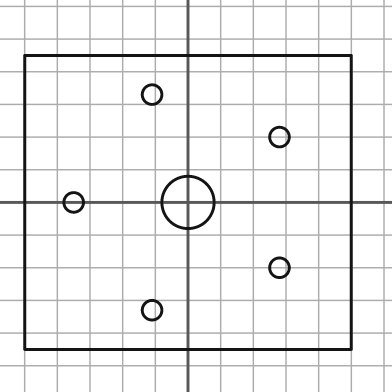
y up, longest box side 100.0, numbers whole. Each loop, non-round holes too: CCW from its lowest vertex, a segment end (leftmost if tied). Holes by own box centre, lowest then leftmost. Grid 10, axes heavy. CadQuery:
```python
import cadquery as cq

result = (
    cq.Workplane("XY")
    .moveTo(-50.0, -45.0)
    .lineTo(50.0, -45.0)
    .lineTo(50.0, 45.0)
    .lineTo(-50.0, 45.0)
    .close()
    .moveTo(-11.0, -33.0)
    .circle(3.0)
    .moveTo(28.0, -20.0)
    .circle(3.0)
    .moveTo(-35.0, 0.0)
    .circle(3.0)
    .moveTo(0.0, 0.0)
    .circle(8.0)
    .moveTo(28.0, 20.0)
    .circle(3.0)
    .moveTo(-11.0, 33.0)
    .circle(3.0)
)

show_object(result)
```